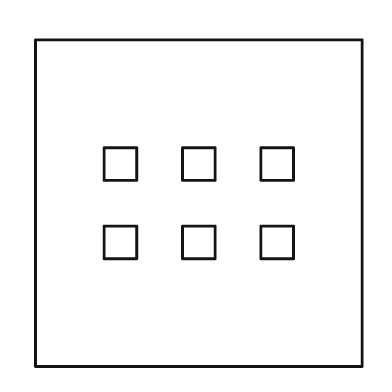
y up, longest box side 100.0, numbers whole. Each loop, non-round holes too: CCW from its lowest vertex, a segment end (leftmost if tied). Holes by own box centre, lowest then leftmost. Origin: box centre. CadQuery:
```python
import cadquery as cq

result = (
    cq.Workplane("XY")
    .moveTo(-50.0, -50.0)
    .lineTo(50.0, -50.0)
    .lineTo(50.0, 50.0)
    .lineTo(-50.0, 50.0)
    .close()
    .moveTo(-29.0, -17.0)
    .lineTo(-19.0, -17.0)
    .lineTo(-19.0, -7.0)
    .lineTo(-29.0, -7.0)
    .close()
    .moveTo(-5.0, -17.0)
    .lineTo(5.0, -17.0)
    .lineTo(5.0, -7.0)
    .lineTo(-5.0, -7.0)
    .close()
    .moveTo(19.0, -17.0)
    .lineTo(29.0, -17.0)
    .lineTo(29.0, -7.0)
    .lineTo(19.0, -7.0)
    .close()
    .moveTo(-29.0, 7.0)
    .lineTo(-19.0, 7.0)
    .lineTo(-19.0, 17.0)
    .lineTo(-29.0, 17.0)
    .close()
    .moveTo(-5.0, 7.0)
    .lineTo(5.0, 7.0)
    .lineTo(5.0, 17.0)
    .lineTo(-5.0, 17.0)
    .close()
    .moveTo(19.0, 7.0)
    .lineTo(29.0, 7.0)
    .lineTo(29.0, 17.0)
    .lineTo(19.0, 17.0)
    .close()
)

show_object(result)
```